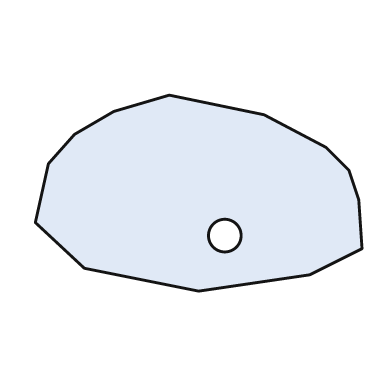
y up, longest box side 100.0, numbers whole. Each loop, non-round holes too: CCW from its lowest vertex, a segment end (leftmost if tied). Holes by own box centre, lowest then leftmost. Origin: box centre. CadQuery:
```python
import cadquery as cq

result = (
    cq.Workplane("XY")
    .moveTo(0.0, -30.0)
    .lineTo(34.0, -25.0)
    .lineTo(50.0, -17.0)
    .lineTo(49.0, -2.0)
    .lineTo(46.0, 7.0)
    .lineTo(39.0, 14.0)
    .lineTo(20.0, 24.0)
    .lineTo(-9.0, 30.0)
    .lineTo(-26.0, 25.0)
    .lineTo(-38.0, 18.0)
    .lineTo(-46.0, 9.0)
    .lineTo(-50.0, -9.0)
    .lineTo(-35.0, -23.0)
    .close()
    .moveTo(8.0, -13.0)
    .circle(5.0)
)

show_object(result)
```